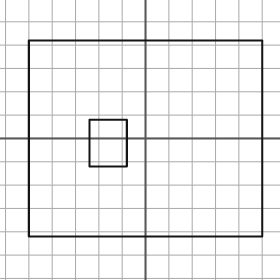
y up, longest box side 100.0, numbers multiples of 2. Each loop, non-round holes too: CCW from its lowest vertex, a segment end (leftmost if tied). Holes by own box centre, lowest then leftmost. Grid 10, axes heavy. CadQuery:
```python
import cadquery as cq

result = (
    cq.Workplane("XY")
    .moveTo(-50.0, -42.0)
    .lineTo(50.0, -42.0)
    .lineTo(50.0, 42.0)
    .lineTo(-50.0, 42.0)
    .close()
    .moveTo(-24.0, -12.0)
    .lineTo(-8.0, -12.0)
    .lineTo(-8.0, 8.0)
    .lineTo(-24.0, 8.0)
    .close()
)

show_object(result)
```